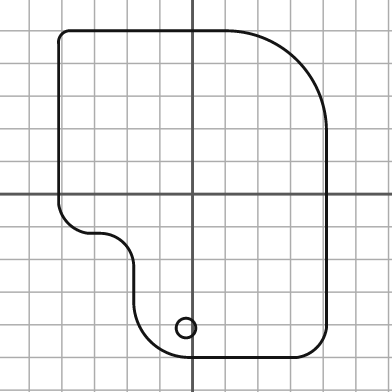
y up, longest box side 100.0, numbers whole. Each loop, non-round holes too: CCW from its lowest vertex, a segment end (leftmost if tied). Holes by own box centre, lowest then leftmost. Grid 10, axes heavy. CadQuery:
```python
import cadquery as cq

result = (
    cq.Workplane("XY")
    .moveTo(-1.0, -50.0)
    .lineTo(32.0, -50.0)
    .threePointArc((38.0, -47.0), (41.0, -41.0))
    .lineTo(41.0, 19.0)
    .threePointArc((32.0, 41.0), (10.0, 50.0))
    .lineTo(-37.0, 50.0)
    .threePointArc((-40.0, 49.0), (-41.0, 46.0))
    .lineTo(-41.0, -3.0)
    .threePointArc((-38.0, -9.0), (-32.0, -12.0))
    .lineTo(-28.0, -12.0)
    .threePointArc((-21.0, -15.0), (-18.0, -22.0))
    .lineTo(-18.0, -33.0)
    .threePointArc((-13.0, -45.0), (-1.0, -50.0))
    .close()
    .moveTo(-2.0, -41.0)
    .circle(3.0)
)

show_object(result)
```